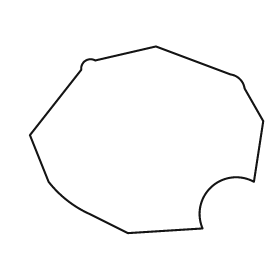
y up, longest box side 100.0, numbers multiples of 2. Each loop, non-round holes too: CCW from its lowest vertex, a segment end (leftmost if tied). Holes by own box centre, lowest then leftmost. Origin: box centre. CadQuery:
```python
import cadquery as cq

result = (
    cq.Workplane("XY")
    .moveTo(-8.0, -40.0)
    .lineTo(24.0, -38.0)
    .threePointArc((28.0, -20.0), (46.0, -18.0))
    .lineTo(50.0, 8.0)
    .lineTo(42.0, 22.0)
    .threePointArc((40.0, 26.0), (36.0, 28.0))
    .lineTo(4.0, 40.0)
    .lineTo(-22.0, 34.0)
    .threePointArc((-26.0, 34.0), (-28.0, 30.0))
    .lineTo(-50.0, 2.0)
    .lineTo(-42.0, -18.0)
    .threePointArc((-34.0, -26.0), (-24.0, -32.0))
    .close()
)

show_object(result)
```